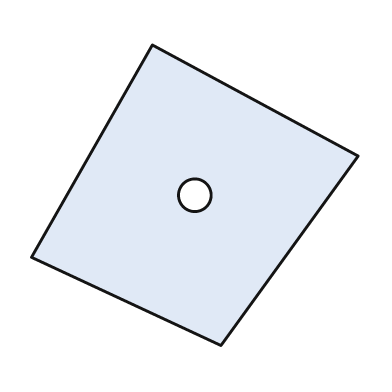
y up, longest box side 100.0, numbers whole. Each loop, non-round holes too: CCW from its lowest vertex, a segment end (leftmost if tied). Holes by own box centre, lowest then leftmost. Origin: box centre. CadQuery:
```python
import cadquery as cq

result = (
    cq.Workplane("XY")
    .moveTo(8.0, -46.0)
    .lineTo(50.0, 12.0)
    .lineTo(-13.0, 46.0)
    .lineTo(-50.0, -19.0)
    .close()
    .moveTo(0.0, 0.0)
    .circle(5.0)
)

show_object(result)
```